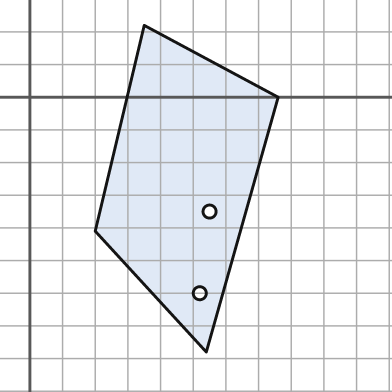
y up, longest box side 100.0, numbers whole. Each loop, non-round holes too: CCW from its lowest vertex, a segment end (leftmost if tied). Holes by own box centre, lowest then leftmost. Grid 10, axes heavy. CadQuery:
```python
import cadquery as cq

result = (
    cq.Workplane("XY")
    .moveTo(54.0, -78.0)
    .lineTo(76.0, 0.0)
    .lineTo(35.0, 22.0)
    .lineTo(20.0, -41.0)
    .close()
    .moveTo(52.0, -60.0)
    .circle(2.0)
    .moveTo(55.0, -35.0)
    .circle(2.0)
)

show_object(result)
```